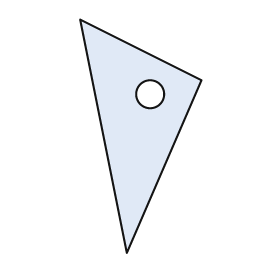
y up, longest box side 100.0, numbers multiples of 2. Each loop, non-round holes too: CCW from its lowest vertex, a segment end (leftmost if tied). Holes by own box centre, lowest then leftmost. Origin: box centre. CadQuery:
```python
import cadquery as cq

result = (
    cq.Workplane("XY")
    .moveTo(-6.0, -50.0)
    .lineTo(26.0, 24.0)
    .lineTo(-26.0, 50.0)
    .close()
    .moveTo(4.0, 18.0)
    .circle(6.0)
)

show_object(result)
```